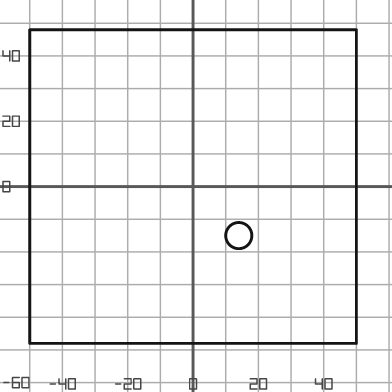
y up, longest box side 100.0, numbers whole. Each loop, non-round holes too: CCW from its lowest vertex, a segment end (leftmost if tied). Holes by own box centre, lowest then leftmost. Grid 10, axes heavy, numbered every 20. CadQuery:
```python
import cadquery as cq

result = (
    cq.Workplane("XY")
    .moveTo(-50.0, -48.0)
    .lineTo(50.0, -48.0)
    .lineTo(50.0, 48.0)
    .lineTo(-50.0, 48.0)
    .close()
    .moveTo(14.0, -15.0)
    .circle(4.0)
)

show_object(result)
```